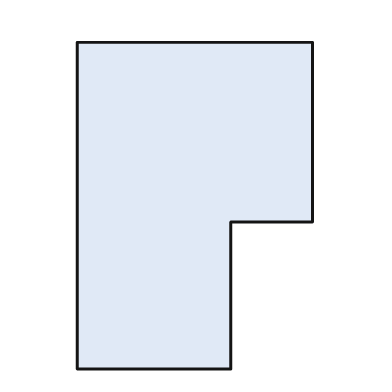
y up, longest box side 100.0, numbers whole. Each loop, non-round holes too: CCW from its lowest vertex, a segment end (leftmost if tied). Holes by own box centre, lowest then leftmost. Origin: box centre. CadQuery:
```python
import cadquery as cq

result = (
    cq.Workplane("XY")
    .moveTo(-36.0, -50.0)
    .lineTo(11.0, -50.0)
    .lineTo(11.0, -5.0)
    .lineTo(36.0, -5.0)
    .lineTo(36.0, 50.0)
    .lineTo(-36.0, 50.0)
    .close()
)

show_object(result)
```